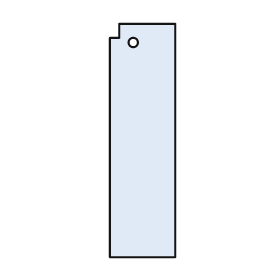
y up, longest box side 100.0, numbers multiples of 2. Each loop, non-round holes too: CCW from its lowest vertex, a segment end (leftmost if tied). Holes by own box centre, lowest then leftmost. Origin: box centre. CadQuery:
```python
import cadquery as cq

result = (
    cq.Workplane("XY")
    .moveTo(-14.0, -50.0)
    .lineTo(14.0, -50.0)
    .lineTo(14.0, 50.0)
    .lineTo(-10.0, 50.0)
    .lineTo(-10.0, 44.0)
    .lineTo(-14.0, 44.0)
    .close()
    .moveTo(-4.0, 42.0)
    .circle(2.0)
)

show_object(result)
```